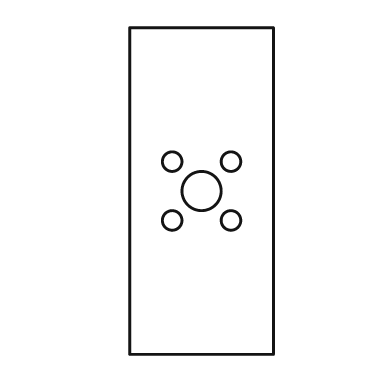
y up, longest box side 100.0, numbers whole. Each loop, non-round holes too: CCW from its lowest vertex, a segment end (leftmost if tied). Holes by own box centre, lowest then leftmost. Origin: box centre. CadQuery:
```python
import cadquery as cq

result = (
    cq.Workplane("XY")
    .moveTo(-22.0, -50.0)
    .lineTo(22.0, -50.0)
    .lineTo(22.0, 50.0)
    .lineTo(-22.0, 50.0)
    .close()
    .moveTo(-9.0, -9.0)
    .circle(3.0)
    .moveTo(9.0, -9.0)
    .circle(3.0)
    .moveTo(0.0, 0.0)
    .circle(6.0)
    .moveTo(-9.0, 9.0)
    .circle(3.0)
    .moveTo(9.0, 9.0)
    .circle(3.0)
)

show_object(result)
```